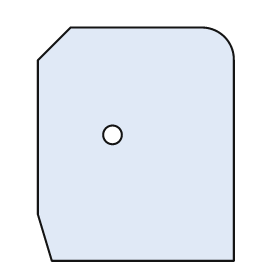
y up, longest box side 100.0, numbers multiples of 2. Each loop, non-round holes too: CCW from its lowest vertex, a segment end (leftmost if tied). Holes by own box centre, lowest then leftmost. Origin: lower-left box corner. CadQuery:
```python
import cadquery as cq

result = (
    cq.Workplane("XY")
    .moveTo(6.0, 0.0)
    .lineTo(84.0, 0.0)
    .lineTo(84.0, 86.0)
    .threePointArc((80.0, 96.0), (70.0, 100.0))
    .lineTo(14.0, 100.0)
    .lineTo(0.0, 86.0)
    .lineTo(0.0, 20.0)
    .close()
    .moveTo(32.0, 54.0)
    .circle(4.0)
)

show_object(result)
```